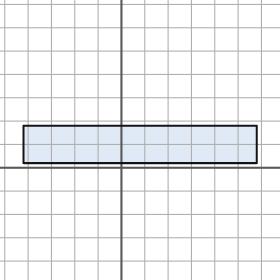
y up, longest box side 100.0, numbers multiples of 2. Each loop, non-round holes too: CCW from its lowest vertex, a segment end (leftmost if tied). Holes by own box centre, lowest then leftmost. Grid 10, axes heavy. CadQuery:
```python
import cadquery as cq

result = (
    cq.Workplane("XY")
    .moveTo(-42.0, 2.0)
    .lineTo(58.0, 2.0)
    .lineTo(58.0, 18.0)
    .lineTo(-42.0, 18.0)
    .close()
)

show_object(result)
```